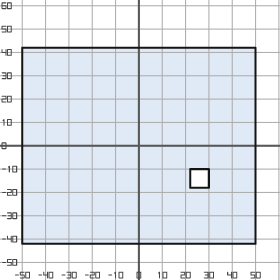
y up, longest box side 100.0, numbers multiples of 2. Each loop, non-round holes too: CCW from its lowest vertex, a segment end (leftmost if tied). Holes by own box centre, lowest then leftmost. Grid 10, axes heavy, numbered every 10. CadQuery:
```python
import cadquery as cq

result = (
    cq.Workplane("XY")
    .moveTo(-50.0, -42.0)
    .lineTo(50.0, -42.0)
    .lineTo(50.0, 42.0)
    .lineTo(-50.0, 42.0)
    .close()
    .moveTo(22.0, -18.0)
    .lineTo(30.0, -18.0)
    .lineTo(30.0, -10.0)
    .lineTo(22.0, -10.0)
    .close()
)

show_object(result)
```